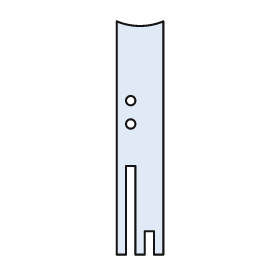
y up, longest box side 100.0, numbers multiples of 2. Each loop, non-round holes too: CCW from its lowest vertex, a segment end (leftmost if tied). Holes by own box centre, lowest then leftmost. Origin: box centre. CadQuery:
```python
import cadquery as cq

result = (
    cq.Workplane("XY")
    .moveTo(-10.0, -50.0)
    .lineTo(-6.0, -50.0)
    .lineTo(-6.0, -12.0)
    .lineTo(-2.0, -12.0)
    .lineTo(-2.0, -50.0)
    .lineTo(2.0, -50.0)
    .lineTo(2.0, -40.0)
    .lineTo(6.0, -40.0)
    .lineTo(6.0, -50.0)
    .lineTo(10.0, -50.0)
    .lineTo(10.0, 50.0)
    .threePointArc((0.0, 48.0), (-10.0, 50.0))
    .close()
    .moveTo(-4.0, 6.0)
    .circle(2.0)
    .moveTo(-4.0, 16.0)
    .circle(2.0)
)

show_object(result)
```